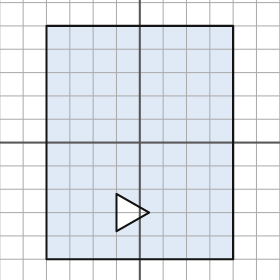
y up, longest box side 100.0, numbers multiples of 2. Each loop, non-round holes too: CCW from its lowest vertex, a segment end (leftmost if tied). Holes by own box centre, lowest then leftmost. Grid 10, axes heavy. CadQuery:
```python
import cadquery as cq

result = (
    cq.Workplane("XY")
    .moveTo(-40.0, -50.0)
    .lineTo(40.0, -50.0)
    .lineTo(40.0, 50.0)
    .lineTo(-40.0, 50.0)
    .close()
    .moveTo(-10.0, -38.0)
    .lineTo(4.0, -30.0)
    .lineTo(-10.0, -22.0)
    .close()
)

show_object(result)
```